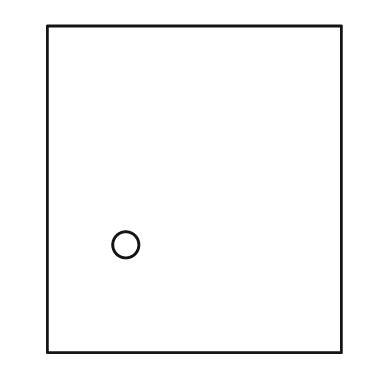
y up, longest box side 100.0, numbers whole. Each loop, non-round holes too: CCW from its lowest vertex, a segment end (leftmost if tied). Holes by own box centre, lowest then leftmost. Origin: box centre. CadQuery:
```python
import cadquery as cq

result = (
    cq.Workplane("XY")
    .moveTo(-45.0, -50.0)
    .lineTo(45.0, -50.0)
    .lineTo(45.0, 50.0)
    .lineTo(-45.0, 50.0)
    .close()
    .moveTo(-21.0, -17.0)
    .circle(4.0)
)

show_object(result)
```